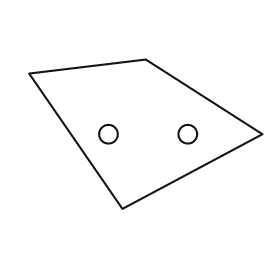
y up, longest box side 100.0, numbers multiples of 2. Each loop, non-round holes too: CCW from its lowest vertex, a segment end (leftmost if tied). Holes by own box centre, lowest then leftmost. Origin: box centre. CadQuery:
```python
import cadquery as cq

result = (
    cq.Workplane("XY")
    .moveTo(-10.0, -32.0)
    .lineTo(50.0, 0.0)
    .lineTo(0.0, 32.0)
    .lineTo(-50.0, 26.0)
    .close()
    .moveTo(-16.0, 0.0)
    .circle(4.0)
    .moveTo(18.0, 0.0)
    .circle(4.0)
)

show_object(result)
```